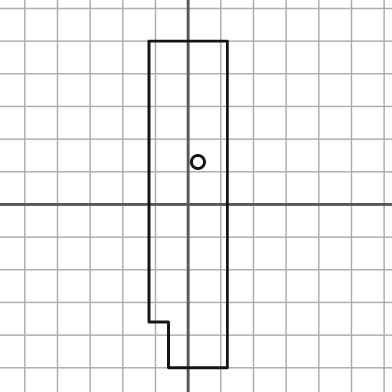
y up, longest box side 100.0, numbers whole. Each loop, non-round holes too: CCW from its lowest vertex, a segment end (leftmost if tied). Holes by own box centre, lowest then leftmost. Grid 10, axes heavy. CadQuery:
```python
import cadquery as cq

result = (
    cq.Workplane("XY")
    .moveTo(-6.0, -50.0)
    .lineTo(12.0, -50.0)
    .lineTo(12.0, 50.0)
    .lineTo(-12.0, 50.0)
    .lineTo(-12.0, -36.0)
    .lineTo(-6.0, -36.0)
    .close()
    .moveTo(3.0, 13.0)
    .circle(2.0)
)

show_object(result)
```